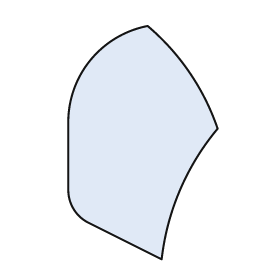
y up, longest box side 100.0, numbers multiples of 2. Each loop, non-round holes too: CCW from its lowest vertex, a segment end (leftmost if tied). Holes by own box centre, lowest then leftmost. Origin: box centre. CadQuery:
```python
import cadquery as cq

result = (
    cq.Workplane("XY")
    .moveTo(8.0, -50.0)
    .threePointArc((16.0, -20.0), (32.0, 6.0))
    .threePointArc((20.0, 30.0), (2.0, 50.0))
    .threePointArc((-22.0, 36.0), (-32.0, 10.0))
    .lineTo(-32.0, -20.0)
    .threePointArc((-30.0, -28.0), (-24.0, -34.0))
    .close()
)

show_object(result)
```